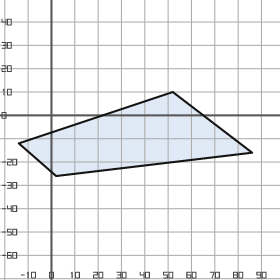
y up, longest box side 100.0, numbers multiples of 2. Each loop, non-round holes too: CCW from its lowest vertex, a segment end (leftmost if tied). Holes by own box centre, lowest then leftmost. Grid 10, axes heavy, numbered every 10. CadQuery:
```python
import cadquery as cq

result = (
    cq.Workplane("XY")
    .moveTo(2.0, -26.0)
    .lineTo(86.0, -16.0)
    .lineTo(52.0, 10.0)
    .lineTo(-14.0, -12.0)
    .close()
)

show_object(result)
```